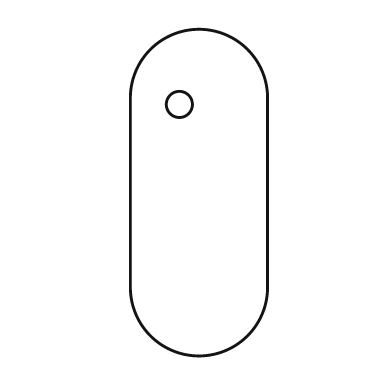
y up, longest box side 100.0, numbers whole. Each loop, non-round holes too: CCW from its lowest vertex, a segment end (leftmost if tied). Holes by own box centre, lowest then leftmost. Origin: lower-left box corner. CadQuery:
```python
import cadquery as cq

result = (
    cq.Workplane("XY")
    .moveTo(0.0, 21.0)
    .threePointArc((21.0, 0.0), (42.0, 21.0))
    .lineTo(42.0, 79.0)
    .threePointArc((21.0, 100.0), (0.0, 79.0))
    .close()
    .moveTo(15.0, 77.0)
    .circle(4.0)
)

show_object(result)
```